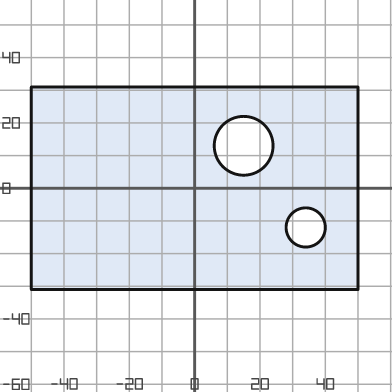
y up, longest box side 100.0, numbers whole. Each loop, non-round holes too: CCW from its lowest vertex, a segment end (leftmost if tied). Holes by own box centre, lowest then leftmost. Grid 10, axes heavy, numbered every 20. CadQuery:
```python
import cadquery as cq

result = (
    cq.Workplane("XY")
    .moveTo(-50.0, -31.0)
    .lineTo(50.0, -31.0)
    .lineTo(50.0, 31.0)
    .lineTo(-50.0, 31.0)
    .close()
    .moveTo(34.0, -12.0)
    .circle(6.0)
    .moveTo(15.0, 13.0)
    .circle(9.0)
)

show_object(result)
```